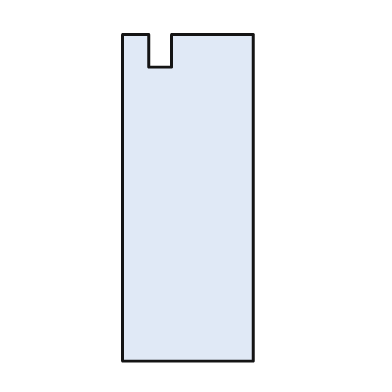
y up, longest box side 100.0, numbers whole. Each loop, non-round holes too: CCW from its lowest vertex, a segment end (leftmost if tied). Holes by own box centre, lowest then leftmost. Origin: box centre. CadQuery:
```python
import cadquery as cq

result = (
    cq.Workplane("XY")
    .moveTo(-20.0, -50.0)
    .lineTo(20.0, -50.0)
    .lineTo(20.0, 50.0)
    .lineTo(-5.0, 50.0)
    .lineTo(-5.0, 40.0)
    .lineTo(-12.0, 40.0)
    .lineTo(-12.0, 50.0)
    .lineTo(-20.0, 50.0)
    .close()
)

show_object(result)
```